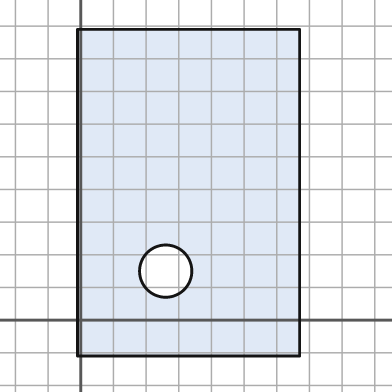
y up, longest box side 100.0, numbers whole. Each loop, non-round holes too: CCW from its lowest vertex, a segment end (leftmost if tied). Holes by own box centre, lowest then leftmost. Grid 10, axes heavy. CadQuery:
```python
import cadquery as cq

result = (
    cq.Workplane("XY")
    .moveTo(-1.0, -11.0)
    .lineTo(67.0, -11.0)
    .lineTo(67.0, 89.0)
    .lineTo(-1.0, 89.0)
    .close()
    .moveTo(26.0, 15.0)
    .circle(8.0)
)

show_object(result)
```